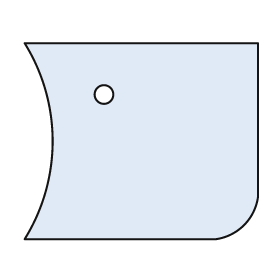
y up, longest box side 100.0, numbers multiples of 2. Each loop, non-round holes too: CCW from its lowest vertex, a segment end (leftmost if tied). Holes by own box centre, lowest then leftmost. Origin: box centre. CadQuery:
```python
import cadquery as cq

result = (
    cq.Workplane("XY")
    .moveTo(-50.0, -42.0)
    .lineTo(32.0, -42.0)
    .threePointArc((44.0, -36.0), (50.0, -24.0))
    .lineTo(50.0, 42.0)
    .lineTo(-50.0, 42.0)
    .threePointArc((-38.0, 0.0), (-50.0, -42.0))
    .close()
    .moveTo(-16.0, 20.0)
    .circle(4.0)
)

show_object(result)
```